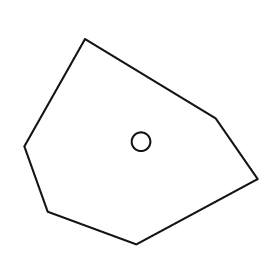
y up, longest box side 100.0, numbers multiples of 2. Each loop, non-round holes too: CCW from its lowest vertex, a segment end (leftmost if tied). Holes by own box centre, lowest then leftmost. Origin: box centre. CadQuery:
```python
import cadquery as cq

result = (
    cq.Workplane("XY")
    .moveTo(-2.0, -44.0)
    .lineTo(50.0, -16.0)
    .lineTo(32.0, 10.0)
    .lineTo(-24.0, 44.0)
    .lineTo(-50.0, -2.0)
    .lineTo(-40.0, -30.0)
    .close()
    .moveTo(0.0, 0.0)
    .circle(4.0)
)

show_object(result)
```